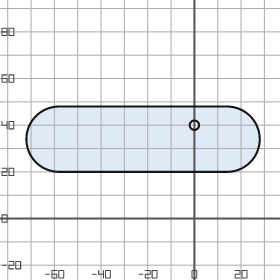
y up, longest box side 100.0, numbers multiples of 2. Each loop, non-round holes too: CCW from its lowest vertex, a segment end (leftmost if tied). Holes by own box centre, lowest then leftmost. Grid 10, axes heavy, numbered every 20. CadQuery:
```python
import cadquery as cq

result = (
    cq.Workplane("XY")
    .moveTo(-58.0, 20.0)
    .lineTo(14.0, 20.0)
    .threePointArc((28.0, 34.0), (14.0, 48.0))
    .lineTo(-58.0, 48.0)
    .threePointArc((-72.0, 34.0), (-58.0, 20.0))
    .close()
    .moveTo(0.0, 40.0)
    .circle(2.0)
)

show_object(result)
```